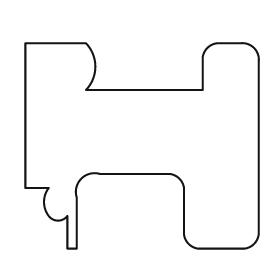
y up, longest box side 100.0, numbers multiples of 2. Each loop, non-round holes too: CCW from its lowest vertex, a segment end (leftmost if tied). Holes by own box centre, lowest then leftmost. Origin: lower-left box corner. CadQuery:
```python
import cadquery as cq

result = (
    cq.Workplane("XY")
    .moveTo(18.0, 0.0)
    .lineTo(22.0, 0.0)
    .lineTo(22.0, 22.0)
    .threePointArc((24.0, 30.0), (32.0, 32.0))
    .lineTo(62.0, 32.0)
    .threePointArc((66.0, 30.0), (68.0, 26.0))
    .lineTo(68.0, 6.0)
    .threePointArc((70.0, 2.0), (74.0, 0.0))
    .lineTo(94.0, 0.0)
    .threePointArc((98.0, 2.0), (100.0, 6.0))
    .lineTo(100.0, 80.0)
    .threePointArc((98.0, 86.0), (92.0, 88.0))
    .lineTo(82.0, 88.0)
    .threePointArc((78.0, 86.0), (76.0, 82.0))
    .lineTo(76.0, 68.0)
    .lineTo(26.0, 68.0)
    .threePointArc((30.0, 78.0), (26.0, 88.0))
    .lineTo(0.0, 88.0)
    .lineTo(0.0, 26.0)
    .lineTo(10.0, 26.0)
    .threePointArc((8.0, 20.0), (10.0, 14.0))
    .threePointArc((14.0, 12.0), (18.0, 14.0))
    .close()
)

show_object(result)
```